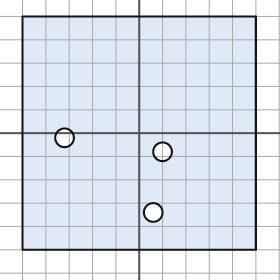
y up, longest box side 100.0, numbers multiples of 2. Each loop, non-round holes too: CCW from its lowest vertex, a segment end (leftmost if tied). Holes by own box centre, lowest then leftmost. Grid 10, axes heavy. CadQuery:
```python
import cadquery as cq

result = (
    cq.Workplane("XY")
    .moveTo(-50.0, -50.0)
    .lineTo(50.0, -50.0)
    .lineTo(50.0, 50.0)
    .lineTo(-50.0, 50.0)
    .close()
    .moveTo(6.0, -34.0)
    .circle(4.0)
    .moveTo(10.0, -8.0)
    .circle(4.0)
    .moveTo(-32.0, -2.0)
    .circle(4.0)
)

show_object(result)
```